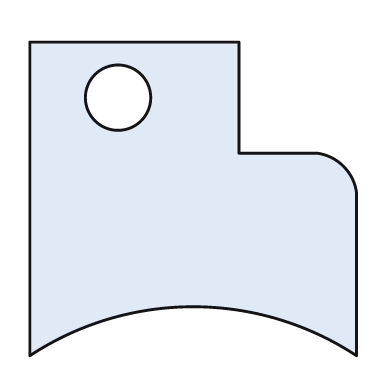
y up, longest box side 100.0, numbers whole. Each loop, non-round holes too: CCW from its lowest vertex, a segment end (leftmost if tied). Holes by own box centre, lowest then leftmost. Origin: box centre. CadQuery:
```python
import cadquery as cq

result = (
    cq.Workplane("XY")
    .moveTo(-50.0, -48.0)
    .threePointArc((0.0, -33.0), (50.0, -48.0))
    .lineTo(50.0, 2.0)
    .threePointArc((46.0, 10.0), (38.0, 14.0))
    .lineTo(14.0, 14.0)
    .lineTo(14.0, 48.0)
    .lineTo(-50.0, 48.0)
    .close()
    .moveTo(-23.0, 31.0)
    .circle(10.0)
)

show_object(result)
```